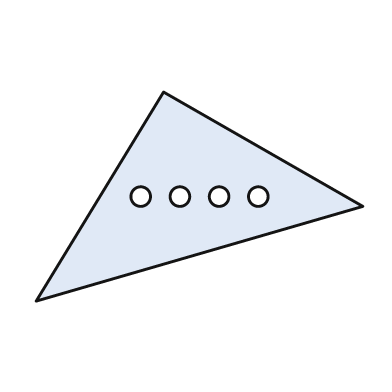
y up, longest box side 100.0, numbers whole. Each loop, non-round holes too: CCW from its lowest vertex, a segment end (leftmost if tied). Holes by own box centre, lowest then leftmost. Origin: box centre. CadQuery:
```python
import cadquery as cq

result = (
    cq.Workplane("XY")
    .moveTo(-50.0, -32.0)
    .lineTo(50.0, -3.0)
    .lineTo(-11.0, 32.0)
    .close()
    .moveTo(-18.0, 0.0)
    .circle(3.0)
    .moveTo(-6.0, 0.0)
    .circle(3.0)
    .moveTo(6.0, 0.0)
    .circle(3.0)
    .moveTo(18.0, 0.0)
    .circle(3.0)
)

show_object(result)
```